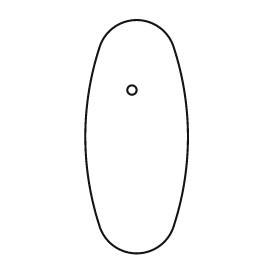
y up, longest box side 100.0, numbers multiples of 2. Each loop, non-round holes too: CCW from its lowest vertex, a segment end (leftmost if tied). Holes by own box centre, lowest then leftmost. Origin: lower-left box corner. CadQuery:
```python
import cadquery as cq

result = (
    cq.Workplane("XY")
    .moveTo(6.0, 12.0)
    .threePointArc((22.0, 0.0), (38.0, 12.0))
    .threePointArc((44.0, 50.0), (38.0, 88.0))
    .threePointArc((22.0, 100.0), (6.0, 88.0))
    .threePointArc((0.0, 50.0), (6.0, 12.0))
    .close()
    .moveTo(20.0, 70.0)
    .circle(2.0)
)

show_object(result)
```